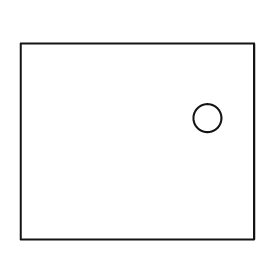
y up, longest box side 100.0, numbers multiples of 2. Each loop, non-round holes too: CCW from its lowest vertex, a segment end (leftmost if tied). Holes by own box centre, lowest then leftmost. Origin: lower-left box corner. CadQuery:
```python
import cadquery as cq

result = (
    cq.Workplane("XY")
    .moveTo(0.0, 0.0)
    .lineTo(100.0, 0.0)
    .lineTo(100.0, 84.0)
    .lineTo(0.0, 84.0)
    .close()
    .moveTo(80.0, 52.0)
    .circle(6.0)
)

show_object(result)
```